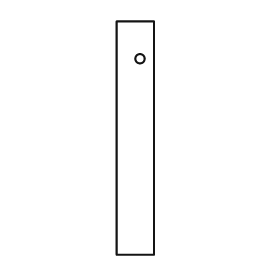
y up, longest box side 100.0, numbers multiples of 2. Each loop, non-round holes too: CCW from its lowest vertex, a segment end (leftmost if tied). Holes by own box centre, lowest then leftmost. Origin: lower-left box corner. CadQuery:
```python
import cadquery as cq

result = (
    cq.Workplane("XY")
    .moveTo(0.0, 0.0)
    .lineTo(16.0, 0.0)
    .lineTo(16.0, 100.0)
    .lineTo(0.0, 100.0)
    .close()
    .moveTo(10.0, 84.0)
    .circle(2.0)
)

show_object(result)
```